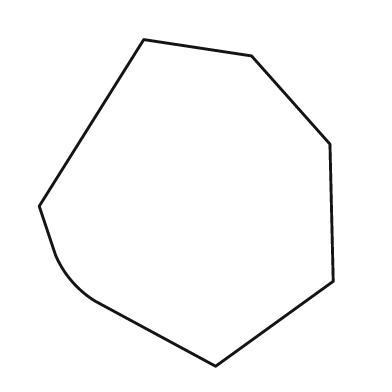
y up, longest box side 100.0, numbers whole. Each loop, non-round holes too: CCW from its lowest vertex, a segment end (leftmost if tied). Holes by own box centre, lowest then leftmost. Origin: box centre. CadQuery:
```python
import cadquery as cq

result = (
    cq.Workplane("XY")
    .moveTo(9.0, -50.0)
    .lineTo(45.0, -24.0)
    .lineTo(44.0, 18.0)
    .lineTo(20.0, 45.0)
    .lineTo(-13.0, 50.0)
    .lineTo(-45.0, -1.0)
    .lineTo(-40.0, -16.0)
    .threePointArc((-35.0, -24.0), (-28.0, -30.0))
    .close()
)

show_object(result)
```